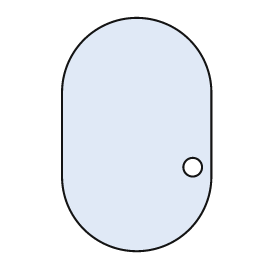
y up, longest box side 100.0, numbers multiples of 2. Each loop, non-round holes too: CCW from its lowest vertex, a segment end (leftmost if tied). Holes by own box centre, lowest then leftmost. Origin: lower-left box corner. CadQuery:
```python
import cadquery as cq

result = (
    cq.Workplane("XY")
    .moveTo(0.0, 32.0)
    .threePointArc((32.0, 0.0), (64.0, 32.0))
    .lineTo(64.0, 68.0)
    .threePointArc((32.0, 100.0), (0.0, 68.0))
    .close()
    .moveTo(56.0, 36.0)
    .circle(4.0)
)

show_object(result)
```